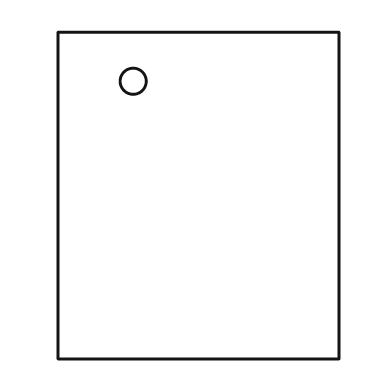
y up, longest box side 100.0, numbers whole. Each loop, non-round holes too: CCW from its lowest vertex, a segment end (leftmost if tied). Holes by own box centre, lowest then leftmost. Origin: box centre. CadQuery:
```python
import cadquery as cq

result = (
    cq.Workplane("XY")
    .moveTo(-43.0, -50.0)
    .lineTo(43.0, -50.0)
    .lineTo(43.0, 50.0)
    .lineTo(-43.0, 50.0)
    .close()
    .moveTo(-20.0, 35.0)
    .circle(4.0)
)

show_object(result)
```